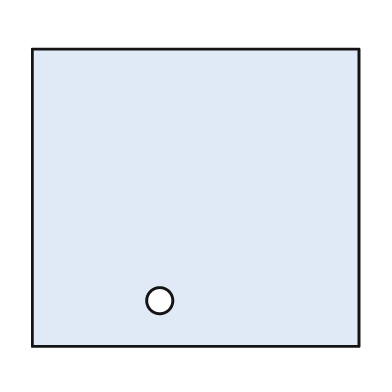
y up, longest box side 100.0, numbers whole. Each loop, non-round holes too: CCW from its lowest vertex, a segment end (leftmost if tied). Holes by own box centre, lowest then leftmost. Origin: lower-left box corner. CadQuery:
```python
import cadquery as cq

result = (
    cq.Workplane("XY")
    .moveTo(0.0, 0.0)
    .lineTo(100.0, 0.0)
    .lineTo(100.0, 91.0)
    .lineTo(0.0, 91.0)
    .close()
    .moveTo(39.0, 14.0)
    .circle(4.0)
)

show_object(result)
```